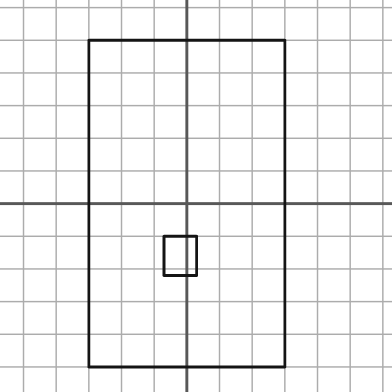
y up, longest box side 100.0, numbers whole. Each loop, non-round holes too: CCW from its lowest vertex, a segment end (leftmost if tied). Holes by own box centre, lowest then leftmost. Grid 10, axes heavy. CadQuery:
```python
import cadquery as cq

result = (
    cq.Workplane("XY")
    .moveTo(-30.0, -50.0)
    .lineTo(30.0, -50.0)
    .lineTo(30.0, 50.0)
    .lineTo(-30.0, 50.0)
    .close()
    .moveTo(-7.0, -22.0)
    .lineTo(3.0, -22.0)
    .lineTo(3.0, -10.0)
    .lineTo(-7.0, -10.0)
    .close()
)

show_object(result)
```